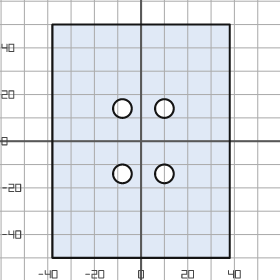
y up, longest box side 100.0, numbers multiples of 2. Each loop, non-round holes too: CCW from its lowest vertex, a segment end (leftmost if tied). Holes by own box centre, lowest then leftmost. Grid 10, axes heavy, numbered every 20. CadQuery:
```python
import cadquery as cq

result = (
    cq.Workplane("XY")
    .moveTo(-38.0, -50.0)
    .lineTo(38.0, -50.0)
    .lineTo(38.0, 50.0)
    .lineTo(-38.0, 50.0)
    .close()
    .moveTo(-8.0, -14.0)
    .circle(4.0)
    .moveTo(10.0, -14.0)
    .circle(4.0)
    .moveTo(-8.0, 14.0)
    .circle(4.0)
    .moveTo(10.0, 14.0)
    .circle(4.0)
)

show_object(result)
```